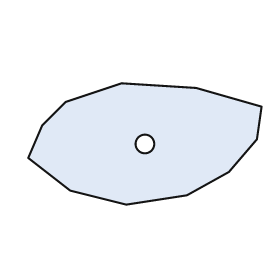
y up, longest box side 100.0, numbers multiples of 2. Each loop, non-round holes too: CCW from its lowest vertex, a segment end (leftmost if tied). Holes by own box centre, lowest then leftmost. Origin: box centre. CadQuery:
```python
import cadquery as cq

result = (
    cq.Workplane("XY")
    .moveTo(-8.0, -26.0)
    .lineTo(18.0, -22.0)
    .lineTo(36.0, -12.0)
    .lineTo(48.0, 2.0)
    .lineTo(50.0, 16.0)
    .lineTo(22.0, 24.0)
    .lineTo(-10.0, 26.0)
    .lineTo(-34.0, 18.0)
    .lineTo(-44.0, 8.0)
    .lineTo(-50.0, -6.0)
    .lineTo(-32.0, -20.0)
    .close()
    .moveTo(0.0, 0.0)
    .circle(4.0)
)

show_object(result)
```